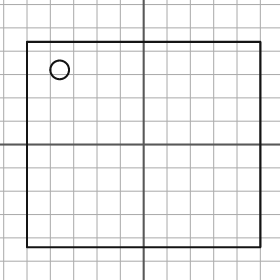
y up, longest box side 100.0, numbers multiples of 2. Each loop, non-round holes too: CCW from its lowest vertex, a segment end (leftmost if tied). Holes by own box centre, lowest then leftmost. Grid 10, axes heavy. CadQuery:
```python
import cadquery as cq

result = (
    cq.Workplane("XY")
    .moveTo(-50.0, -44.0)
    .lineTo(50.0, -44.0)
    .lineTo(50.0, 44.0)
    .lineTo(-50.0, 44.0)
    .close()
    .moveTo(-36.0, 32.0)
    .circle(4.0)
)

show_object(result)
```